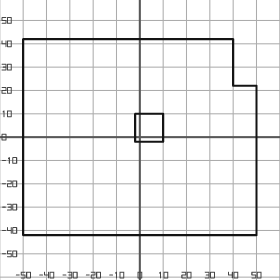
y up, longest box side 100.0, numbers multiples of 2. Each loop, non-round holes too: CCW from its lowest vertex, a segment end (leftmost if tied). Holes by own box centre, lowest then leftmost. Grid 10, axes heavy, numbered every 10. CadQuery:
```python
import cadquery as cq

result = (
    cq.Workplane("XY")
    .moveTo(-50.0, -42.0)
    .lineTo(50.0, -42.0)
    .lineTo(50.0, 22.0)
    .lineTo(40.0, 22.0)
    .lineTo(40.0, 42.0)
    .lineTo(-50.0, 42.0)
    .close()
    .moveTo(-2.0, -2.0)
    .lineTo(10.0, -2.0)
    .lineTo(10.0, 10.0)
    .lineTo(-2.0, 10.0)
    .close()
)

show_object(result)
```